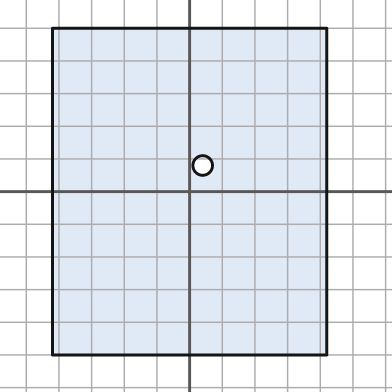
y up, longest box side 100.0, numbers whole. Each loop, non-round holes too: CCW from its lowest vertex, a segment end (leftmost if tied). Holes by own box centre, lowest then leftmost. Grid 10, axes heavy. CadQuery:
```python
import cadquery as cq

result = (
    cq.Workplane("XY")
    .moveTo(-42.0, -50.0)
    .lineTo(42.0, -50.0)
    .lineTo(42.0, 50.0)
    .lineTo(-42.0, 50.0)
    .close()
    .moveTo(4.0, 8.0)
    .circle(3.0)
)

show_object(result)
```